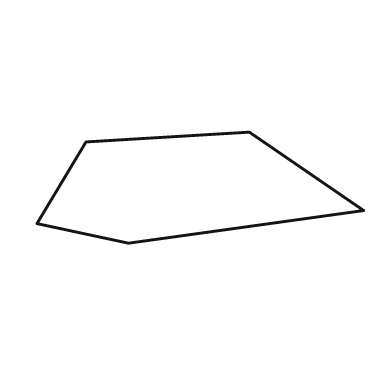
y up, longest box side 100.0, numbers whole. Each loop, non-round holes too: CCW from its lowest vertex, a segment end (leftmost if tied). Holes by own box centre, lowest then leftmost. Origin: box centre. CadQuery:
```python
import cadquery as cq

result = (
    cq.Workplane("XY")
    .moveTo(-22.0, -17.0)
    .lineTo(50.0, -7.0)
    .lineTo(15.0, 17.0)
    .lineTo(-35.0, 14.0)
    .lineTo(-50.0, -11.0)
    .close()
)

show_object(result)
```